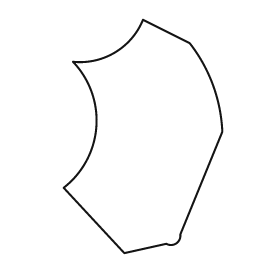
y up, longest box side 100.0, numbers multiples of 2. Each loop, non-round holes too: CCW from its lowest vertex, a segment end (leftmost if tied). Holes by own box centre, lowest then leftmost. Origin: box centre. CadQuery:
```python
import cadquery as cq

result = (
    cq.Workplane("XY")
    .moveTo(-8.0, -50.0)
    .lineTo(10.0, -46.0)
    .threePointArc((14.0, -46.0), (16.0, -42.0))
    .lineTo(34.0, 2.0)
    .threePointArc((30.0, 22.0), (20.0, 40.0))
    .lineTo(0.0, 50.0)
    .threePointArc((-12.0, 36.0), (-30.0, 32.0))
    .threePointArc((-20.0, 4.0), (-34.0, -22.0))
    .close()
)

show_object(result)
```